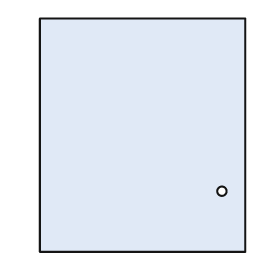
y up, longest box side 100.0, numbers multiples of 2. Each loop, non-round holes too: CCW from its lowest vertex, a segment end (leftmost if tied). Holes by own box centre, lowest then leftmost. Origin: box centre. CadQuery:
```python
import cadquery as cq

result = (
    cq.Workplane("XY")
    .moveTo(-44.0, -50.0)
    .lineTo(44.0, -50.0)
    .lineTo(44.0, 50.0)
    .lineTo(-44.0, 50.0)
    .close()
    .moveTo(34.0, -24.0)
    .circle(2.0)
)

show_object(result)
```